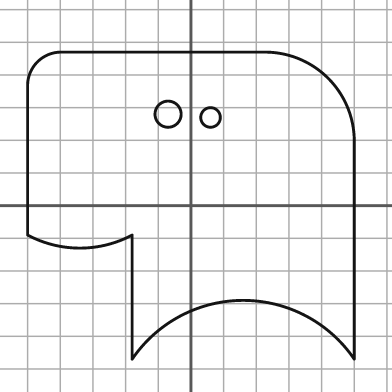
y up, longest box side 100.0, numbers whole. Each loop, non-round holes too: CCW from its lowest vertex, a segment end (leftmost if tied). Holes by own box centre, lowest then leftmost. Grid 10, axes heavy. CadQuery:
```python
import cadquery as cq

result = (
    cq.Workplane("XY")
    .moveTo(-18.0, -47.0)
    .threePointArc((16.0, -29.0), (50.0, -47.0))
    .lineTo(50.0, 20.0)
    .threePointArc((42.0, 39.0), (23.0, 47.0))
    .lineTo(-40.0, 47.0)
    .threePointArc((-47.0, 44.0), (-50.0, 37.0))
    .lineTo(-50.0, -9.0)
    .threePointArc((-34.0, -13.0), (-18.0, -9.0))
    .close()
    .moveTo(6.0, 27.0)
    .circle(3.0)
    .moveTo(-7.0, 28.0)
    .circle(4.0)
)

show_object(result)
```